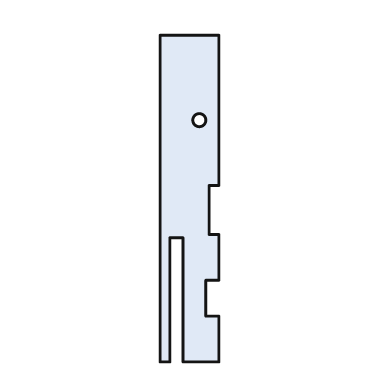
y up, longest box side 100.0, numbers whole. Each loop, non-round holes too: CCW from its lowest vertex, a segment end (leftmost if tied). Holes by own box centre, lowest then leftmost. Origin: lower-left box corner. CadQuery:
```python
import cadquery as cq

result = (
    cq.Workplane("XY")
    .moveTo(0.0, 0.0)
    .lineTo(3.0, 0.0)
    .lineTo(3.0, 38.0)
    .lineTo(7.0, 38.0)
    .lineTo(7.0, 0.0)
    .lineTo(18.0, 0.0)
    .lineTo(18.0, 14.0)
    .lineTo(14.0, 14.0)
    .lineTo(14.0, 25.0)
    .lineTo(18.0, 25.0)
    .lineTo(18.0, 39.0)
    .lineTo(15.0, 39.0)
    .lineTo(15.0, 54.0)
    .lineTo(18.0, 54.0)
    .lineTo(18.0, 100.0)
    .lineTo(0.0, 100.0)
    .close()
    .moveTo(12.0, 74.0)
    .circle(2.0)
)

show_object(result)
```